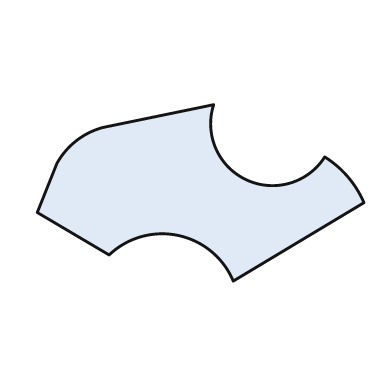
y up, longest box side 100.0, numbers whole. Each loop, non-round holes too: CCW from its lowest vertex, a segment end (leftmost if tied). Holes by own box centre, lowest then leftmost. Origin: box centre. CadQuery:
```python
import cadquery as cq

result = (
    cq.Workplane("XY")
    .moveTo(10.0, -27.0)
    .lineTo(50.0, -3.0)
    .threePointArc((45.0, 5.0), (38.0, 11.0))
    .threePointArc((14.0, 4.0), (4.0, 27.0))
    .lineTo(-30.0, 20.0)
    .threePointArc((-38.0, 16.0), (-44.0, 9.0))
    .lineTo(-50.0, -6.0)
    .lineTo(-28.0, -19.0)
    .threePointArc((-7.0, -13.0), (10.0, -27.0))
    .close()
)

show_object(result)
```